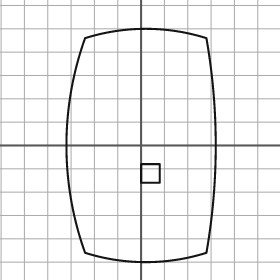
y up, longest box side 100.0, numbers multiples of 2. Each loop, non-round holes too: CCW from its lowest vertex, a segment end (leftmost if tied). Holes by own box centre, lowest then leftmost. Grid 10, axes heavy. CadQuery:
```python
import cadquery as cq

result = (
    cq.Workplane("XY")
    .moveTo(-24.0, -46.0)
    .threePointArc((2.0, -50.0), (28.0, -46.0))
    .threePointArc((32.0, 0.0), (28.0, 46.0))
    .threePointArc((2.0, 50.0), (-24.0, 46.0))
    .threePointArc((-32.0, 0.0), (-24.0, -46.0))
    .close()
    .moveTo(0.0, -16.0)
    .lineTo(8.0, -16.0)
    .lineTo(8.0, -8.0)
    .lineTo(0.0, -8.0)
    .close()
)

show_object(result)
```